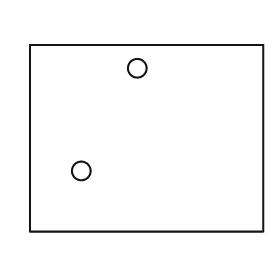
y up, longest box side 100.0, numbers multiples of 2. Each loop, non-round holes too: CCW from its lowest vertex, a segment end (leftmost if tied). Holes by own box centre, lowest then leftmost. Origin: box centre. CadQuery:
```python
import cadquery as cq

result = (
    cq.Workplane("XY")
    .moveTo(-50.0, -40.0)
    .lineTo(50.0, -40.0)
    .lineTo(50.0, 40.0)
    .lineTo(-50.0, 40.0)
    .close()
    .moveTo(-28.0, -14.0)
    .circle(4.0)
    .moveTo(-4.0, 30.0)
    .circle(4.0)
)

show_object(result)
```